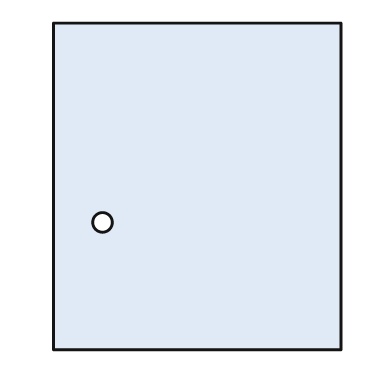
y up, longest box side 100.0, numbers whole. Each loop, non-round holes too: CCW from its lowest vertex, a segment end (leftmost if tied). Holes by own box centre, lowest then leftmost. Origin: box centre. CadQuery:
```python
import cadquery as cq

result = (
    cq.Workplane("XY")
    .moveTo(-44.0, -50.0)
    .lineTo(44.0, -50.0)
    .lineTo(44.0, 50.0)
    .lineTo(-44.0, 50.0)
    .close()
    .moveTo(-29.0, -11.0)
    .circle(3.0)
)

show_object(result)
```